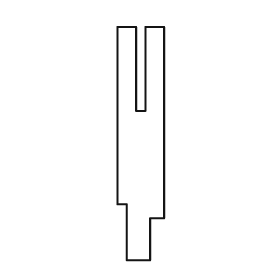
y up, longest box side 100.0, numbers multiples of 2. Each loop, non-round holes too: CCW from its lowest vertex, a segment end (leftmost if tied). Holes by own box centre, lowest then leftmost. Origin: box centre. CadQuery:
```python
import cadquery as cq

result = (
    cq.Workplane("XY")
    .moveTo(-6.0, -50.0)
    .lineTo(4.0, -50.0)
    .lineTo(4.0, -32.0)
    .lineTo(10.0, -32.0)
    .lineTo(10.0, 50.0)
    .lineTo(2.0, 50.0)
    .lineTo(2.0, 14.0)
    .lineTo(-2.0, 14.0)
    .lineTo(-2.0, 50.0)
    .lineTo(-10.0, 50.0)
    .lineTo(-10.0, -26.0)
    .lineTo(-6.0, -26.0)
    .close()
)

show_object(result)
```